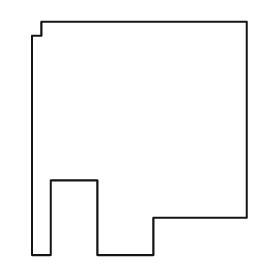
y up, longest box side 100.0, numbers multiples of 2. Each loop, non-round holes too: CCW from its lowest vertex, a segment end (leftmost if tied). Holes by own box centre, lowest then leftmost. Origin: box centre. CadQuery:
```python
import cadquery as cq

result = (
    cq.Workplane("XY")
    .moveTo(-46.0, -50.0)
    .lineTo(-38.0, -50.0)
    .lineTo(-38.0, -18.0)
    .lineTo(-18.0, -18.0)
    .lineTo(-18.0, -50.0)
    .lineTo(6.0, -50.0)
    .lineTo(6.0, -34.0)
    .lineTo(46.0, -34.0)
    .lineTo(46.0, 50.0)
    .lineTo(-42.0, 50.0)
    .lineTo(-42.0, 44.0)
    .lineTo(-46.0, 44.0)
    .close()
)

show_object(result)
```